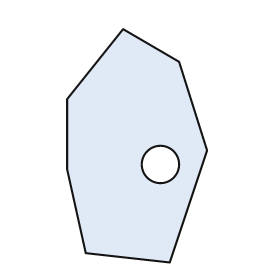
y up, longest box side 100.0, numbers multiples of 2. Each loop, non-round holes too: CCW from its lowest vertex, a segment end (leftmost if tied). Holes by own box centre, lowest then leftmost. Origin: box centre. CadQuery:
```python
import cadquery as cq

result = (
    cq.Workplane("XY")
    .moveTo(14.0, -50.0)
    .lineTo(30.0, -2.0)
    .lineTo(18.0, 36.0)
    .lineTo(-6.0, 50.0)
    .lineTo(-30.0, 20.0)
    .lineTo(-30.0, -10.0)
    .lineTo(-22.0, -46.0)
    .close()
    .moveTo(10.0, -8.0)
    .circle(8.0)
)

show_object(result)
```